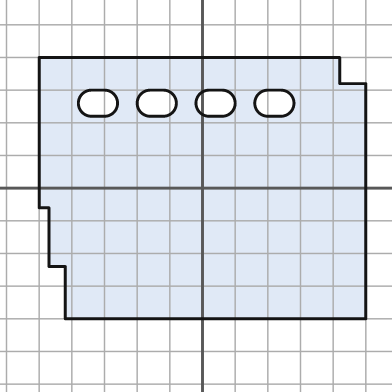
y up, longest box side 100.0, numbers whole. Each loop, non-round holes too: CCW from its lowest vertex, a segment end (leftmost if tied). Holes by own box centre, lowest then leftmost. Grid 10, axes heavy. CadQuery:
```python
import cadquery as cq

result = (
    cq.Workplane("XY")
    .moveTo(-42.0, -40.0)
    .lineTo(50.0, -40.0)
    .lineTo(50.0, 32.0)
    .lineTo(42.0, 32.0)
    .lineTo(42.0, 40.0)
    .lineTo(-50.0, 40.0)
    .lineTo(-50.0, -6.0)
    .lineTo(-47.0, -6.0)
    .lineTo(-47.0, -24.0)
    .lineTo(-42.0, -24.0)
    .close()
    .moveTo(-34.0, 22.0)
    .lineTo(-30.0, 22.0)
    .threePointArc((-26.0, 26.0), (-30.0, 30.0))
    .lineTo(-34.0, 30.0)
    .threePointArc((-38.0, 26.0), (-34.0, 22.0))
    .close()
    .moveTo(-16.0, 22.0)
    .lineTo(-12.0, 22.0)
    .threePointArc((-8.0, 26.0), (-12.0, 30.0))
    .lineTo(-16.0, 30.0)
    .threePointArc((-20.0, 26.0), (-16.0, 22.0))
    .close()
    .moveTo(2.0, 22.0)
    .lineTo(6.0, 22.0)
    .threePointArc((10.0, 26.0), (6.0, 30.0))
    .lineTo(2.0, 30.0)
    .threePointArc((-2.0, 26.0), (2.0, 22.0))
    .close()
    .moveTo(20.0, 22.0)
    .lineTo(24.0, 22.0)
    .threePointArc((28.0, 26.0), (24.0, 30.0))
    .lineTo(20.0, 30.0)
    .threePointArc((16.0, 26.0), (20.0, 22.0))
    .close()
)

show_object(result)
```